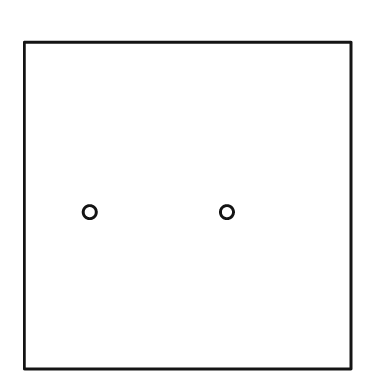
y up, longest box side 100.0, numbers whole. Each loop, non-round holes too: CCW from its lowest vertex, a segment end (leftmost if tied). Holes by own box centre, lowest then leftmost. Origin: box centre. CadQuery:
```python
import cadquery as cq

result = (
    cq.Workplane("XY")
    .moveTo(-50.0, -50.0)
    .lineTo(50.0, -50.0)
    .lineTo(50.0, 50.0)
    .lineTo(-50.0, 50.0)
    .close()
    .moveTo(-30.0, -2.0)
    .circle(2.0)
    .moveTo(12.0, -2.0)
    .circle(2.0)
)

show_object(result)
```